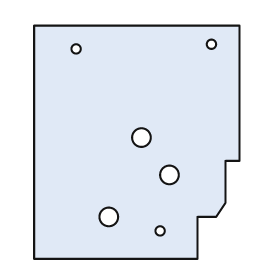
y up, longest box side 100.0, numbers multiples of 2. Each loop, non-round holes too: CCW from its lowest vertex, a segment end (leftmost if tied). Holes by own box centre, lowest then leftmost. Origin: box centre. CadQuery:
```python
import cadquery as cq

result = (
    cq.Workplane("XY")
    .moveTo(-44.0, -50.0)
    .lineTo(26.0, -50.0)
    .lineTo(26.0, -32.0)
    .lineTo(34.0, -32.0)
    .lineTo(38.0, -26.0)
    .lineTo(38.0, -8.0)
    .lineTo(44.0, -8.0)
    .lineTo(44.0, 50.0)
    .lineTo(-44.0, 50.0)
    .close()
    .moveTo(10.0, -38.0)
    .circle(2.0)
    .moveTo(-12.0, -32.0)
    .circle(4.0)
    .moveTo(14.0, -14.0)
    .circle(4.0)
    .moveTo(2.0, 2.0)
    .circle(4.0)
    .moveTo(-26.0, 40.0)
    .circle(2.0)
    .moveTo(32.0, 42.0)
    .circle(2.0)
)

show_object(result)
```